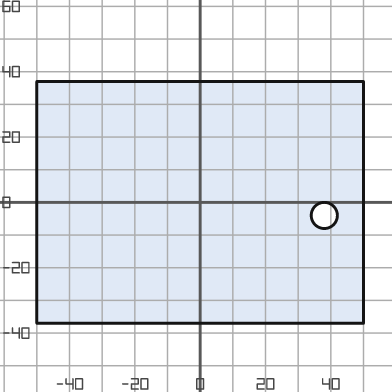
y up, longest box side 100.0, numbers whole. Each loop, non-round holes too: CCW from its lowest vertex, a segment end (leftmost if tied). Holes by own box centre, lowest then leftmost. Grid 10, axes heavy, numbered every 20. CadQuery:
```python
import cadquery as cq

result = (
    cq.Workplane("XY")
    .moveTo(-50.0, -37.0)
    .lineTo(50.0, -37.0)
    .lineTo(50.0, 37.0)
    .lineTo(-50.0, 37.0)
    .close()
    .moveTo(38.0, -4.0)
    .circle(4.0)
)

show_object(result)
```